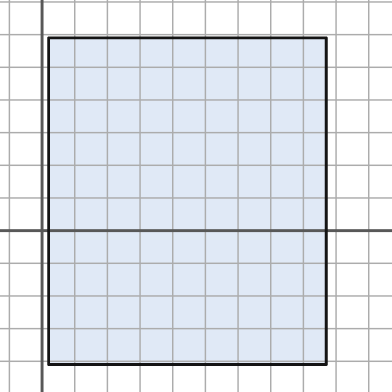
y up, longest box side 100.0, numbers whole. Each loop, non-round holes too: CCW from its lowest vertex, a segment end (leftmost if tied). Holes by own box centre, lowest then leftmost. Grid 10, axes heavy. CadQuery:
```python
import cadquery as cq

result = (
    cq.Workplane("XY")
    .moveTo(2.0, -41.0)
    .lineTo(87.0, -41.0)
    .lineTo(87.0, 59.0)
    .lineTo(2.0, 59.0)
    .close()
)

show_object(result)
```